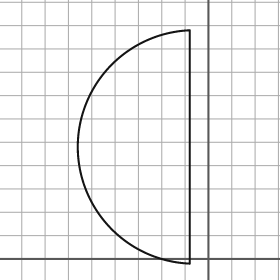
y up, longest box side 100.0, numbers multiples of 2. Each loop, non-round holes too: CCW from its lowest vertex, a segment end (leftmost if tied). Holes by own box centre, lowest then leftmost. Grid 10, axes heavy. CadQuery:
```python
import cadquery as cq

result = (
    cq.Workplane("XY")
    .moveTo(-8.0, -2.0)
    .lineTo(-8.0, 98.0)
    .threePointArc((-56.0, 48.0), (-8.0, -2.0))
    .close()
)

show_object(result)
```